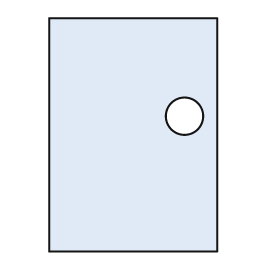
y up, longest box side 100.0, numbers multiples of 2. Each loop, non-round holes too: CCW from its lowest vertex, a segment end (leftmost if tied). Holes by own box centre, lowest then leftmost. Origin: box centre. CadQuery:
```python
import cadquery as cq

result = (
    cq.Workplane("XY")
    .moveTo(-36.0, -50.0)
    .lineTo(36.0, -50.0)
    .lineTo(36.0, 50.0)
    .lineTo(-36.0, 50.0)
    .close()
    .moveTo(22.0, 8.0)
    .circle(8.0)
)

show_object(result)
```